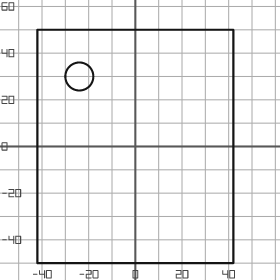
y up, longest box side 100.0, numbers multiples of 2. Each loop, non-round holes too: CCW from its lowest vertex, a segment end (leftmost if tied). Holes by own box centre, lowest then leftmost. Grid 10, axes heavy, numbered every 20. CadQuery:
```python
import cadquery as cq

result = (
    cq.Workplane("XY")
    .moveTo(-42.0, -50.0)
    .lineTo(42.0, -50.0)
    .lineTo(42.0, 50.0)
    .lineTo(-42.0, 50.0)
    .close()
    .moveTo(-24.0, 30.0)
    .circle(6.0)
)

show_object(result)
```